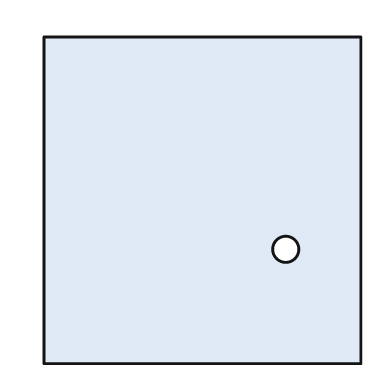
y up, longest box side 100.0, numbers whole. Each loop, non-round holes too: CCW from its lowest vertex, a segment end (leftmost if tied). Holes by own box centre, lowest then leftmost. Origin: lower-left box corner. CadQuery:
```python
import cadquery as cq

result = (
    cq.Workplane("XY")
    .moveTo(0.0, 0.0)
    .lineTo(97.0, 0.0)
    .lineTo(97.0, 100.0)
    .lineTo(0.0, 100.0)
    .close()
    .moveTo(74.0, 35.0)
    .circle(4.0)
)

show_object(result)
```